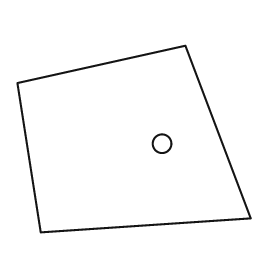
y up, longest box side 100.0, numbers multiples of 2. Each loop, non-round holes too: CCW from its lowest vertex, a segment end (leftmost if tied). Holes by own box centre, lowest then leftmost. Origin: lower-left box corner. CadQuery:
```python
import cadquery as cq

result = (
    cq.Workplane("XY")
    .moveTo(10.0, 0.0)
    .lineTo(100.0, 6.0)
    .lineTo(72.0, 80.0)
    .lineTo(0.0, 64.0)
    .close()
    .moveTo(62.0, 38.0)
    .circle(4.0)
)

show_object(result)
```